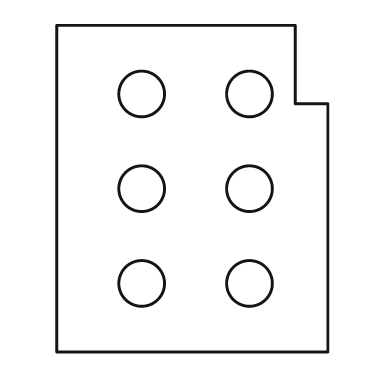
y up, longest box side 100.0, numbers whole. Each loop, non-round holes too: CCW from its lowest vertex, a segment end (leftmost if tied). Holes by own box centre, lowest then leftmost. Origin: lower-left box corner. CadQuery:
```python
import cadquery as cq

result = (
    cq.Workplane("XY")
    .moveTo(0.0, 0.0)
    .lineTo(83.0, 0.0)
    .lineTo(83.0, 76.0)
    .lineTo(73.0, 76.0)
    .lineTo(73.0, 100.0)
    .lineTo(0.0, 100.0)
    .close()
    .moveTo(26.0, 21.0)
    .circle(7.0)
    .moveTo(59.0, 21.0)
    .circle(7.0)
    .moveTo(26.0, 50.0)
    .circle(7.0)
    .moveTo(59.0, 50.0)
    .circle(7.0)
    .moveTo(26.0, 79.0)
    .circle(7.0)
    .moveTo(59.0, 79.0)
    .circle(7.0)
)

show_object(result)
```